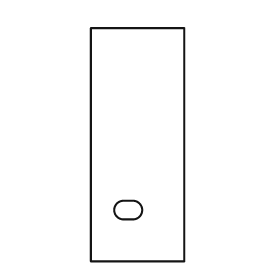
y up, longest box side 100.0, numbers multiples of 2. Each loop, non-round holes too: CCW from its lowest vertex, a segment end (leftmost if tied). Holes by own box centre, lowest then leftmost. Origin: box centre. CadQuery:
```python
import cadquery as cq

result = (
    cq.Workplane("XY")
    .moveTo(-20.0, -50.0)
    .lineTo(20.0, -50.0)
    .lineTo(20.0, 50.0)
    .lineTo(-20.0, 50.0)
    .close()
    .moveTo(-6.0, -32.0)
    .lineTo(-2.0, -32.0)
    .threePointArc((2.0, -28.0), (-2.0, -24.0))
    .lineTo(-6.0, -24.0)
    .threePointArc((-10.0, -28.0), (-6.0, -32.0))
    .close()
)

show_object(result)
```